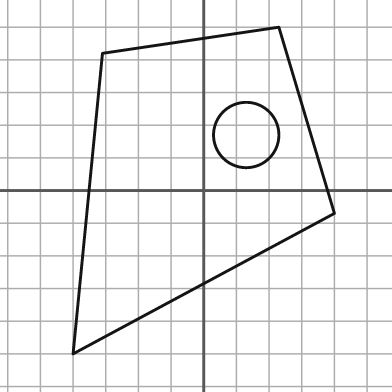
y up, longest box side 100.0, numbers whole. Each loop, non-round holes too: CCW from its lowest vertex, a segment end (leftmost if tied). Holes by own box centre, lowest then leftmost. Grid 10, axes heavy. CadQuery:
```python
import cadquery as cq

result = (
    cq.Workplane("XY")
    .moveTo(-40.0, -50.0)
    .lineTo(40.0, -7.0)
    .lineTo(23.0, 50.0)
    .lineTo(-31.0, 42.0)
    .close()
    .moveTo(13.0, 17.0)
    .circle(10.0)
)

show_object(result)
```